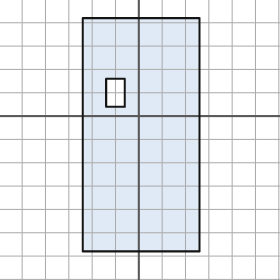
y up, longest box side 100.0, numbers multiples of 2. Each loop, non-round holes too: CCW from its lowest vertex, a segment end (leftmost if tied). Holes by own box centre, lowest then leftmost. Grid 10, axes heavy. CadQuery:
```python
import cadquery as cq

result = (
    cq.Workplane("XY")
    .moveTo(-24.0, -58.0)
    .lineTo(26.0, -58.0)
    .lineTo(26.0, 42.0)
    .lineTo(-24.0, 42.0)
    .close()
    .moveTo(-14.0, 4.0)
    .lineTo(-6.0, 4.0)
    .lineTo(-6.0, 16.0)
    .lineTo(-14.0, 16.0)
    .close()
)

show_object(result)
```